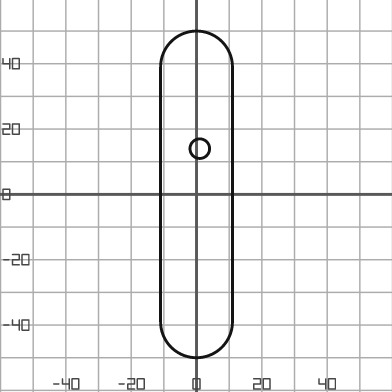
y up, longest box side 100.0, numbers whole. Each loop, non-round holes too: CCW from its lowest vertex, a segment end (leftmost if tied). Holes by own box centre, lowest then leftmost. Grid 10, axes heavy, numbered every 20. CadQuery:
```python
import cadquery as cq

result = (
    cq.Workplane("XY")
    .moveTo(-11.0, -39.0)
    .threePointArc((0.0, -50.0), (11.0, -39.0))
    .lineTo(11.0, 39.0)
    .threePointArc((0.0, 50.0), (-11.0, 39.0))
    .close()
    .moveTo(1.0, 14.0)
    .circle(3.0)
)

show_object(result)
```